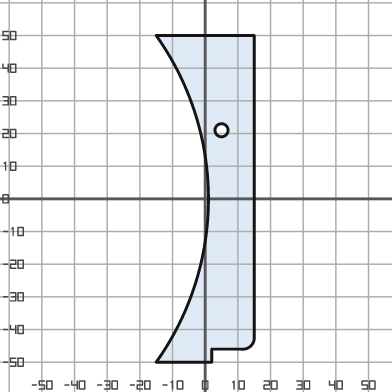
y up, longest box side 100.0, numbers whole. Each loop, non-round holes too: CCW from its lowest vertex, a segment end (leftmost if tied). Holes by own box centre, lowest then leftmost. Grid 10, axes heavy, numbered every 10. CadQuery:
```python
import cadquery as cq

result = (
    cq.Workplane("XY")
    .moveTo(-15.0, -50.0)
    .lineTo(2.0, -50.0)
    .lineTo(2.0, -46.0)
    .lineTo(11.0, -46.0)
    .threePointArc((14.0, -45.0), (15.0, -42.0))
    .lineTo(15.0, 50.0)
    .lineTo(-15.0, 50.0)
    .threePointArc((1.0, 0.0), (-15.0, -50.0))
    .close()
    .moveTo(5.0, 21.0)
    .circle(2.0)
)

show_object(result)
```